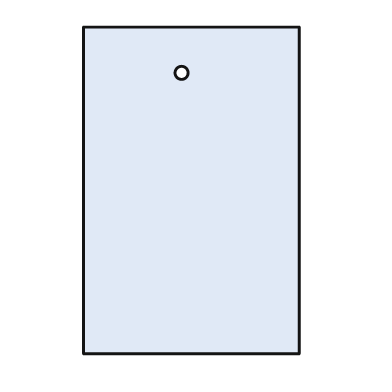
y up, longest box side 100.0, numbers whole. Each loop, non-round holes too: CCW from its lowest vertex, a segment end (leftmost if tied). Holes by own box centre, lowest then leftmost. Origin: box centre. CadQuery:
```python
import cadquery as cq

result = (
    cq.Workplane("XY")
    .moveTo(-33.0, -50.0)
    .lineTo(33.0, -50.0)
    .lineTo(33.0, 50.0)
    .lineTo(-33.0, 50.0)
    .close()
    .moveTo(-3.0, 36.0)
    .circle(2.0)
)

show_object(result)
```